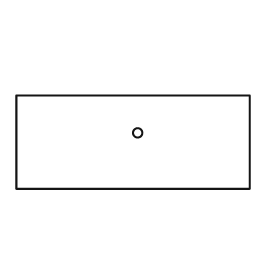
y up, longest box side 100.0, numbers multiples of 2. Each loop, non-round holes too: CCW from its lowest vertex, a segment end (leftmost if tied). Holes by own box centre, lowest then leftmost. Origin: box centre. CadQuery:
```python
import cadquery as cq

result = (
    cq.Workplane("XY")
    .moveTo(-50.0, -20.0)
    .lineTo(50.0, -20.0)
    .lineTo(50.0, 20.0)
    .lineTo(-50.0, 20.0)
    .close()
    .moveTo(2.0, 4.0)
    .circle(2.0)
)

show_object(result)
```